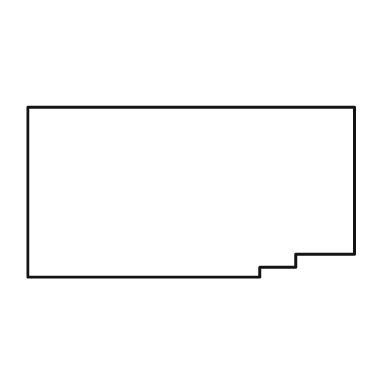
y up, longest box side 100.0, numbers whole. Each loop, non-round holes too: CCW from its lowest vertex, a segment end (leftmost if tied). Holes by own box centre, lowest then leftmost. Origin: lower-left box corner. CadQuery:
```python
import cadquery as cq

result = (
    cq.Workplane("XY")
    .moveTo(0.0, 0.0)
    .lineTo(71.0, 0.0)
    .lineTo(71.0, 3.0)
    .lineTo(82.0, 3.0)
    .lineTo(82.0, 7.0)
    .lineTo(100.0, 7.0)
    .lineTo(100.0, 52.0)
    .lineTo(0.0, 52.0)
    .close()
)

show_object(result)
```